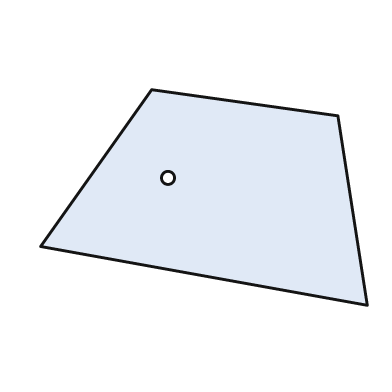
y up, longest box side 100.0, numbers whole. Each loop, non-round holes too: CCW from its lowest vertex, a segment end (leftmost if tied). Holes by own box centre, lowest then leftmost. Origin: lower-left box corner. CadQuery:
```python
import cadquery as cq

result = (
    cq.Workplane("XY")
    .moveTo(100.0, 0.0)
    .lineTo(91.0, 58.0)
    .lineTo(34.0, 66.0)
    .lineTo(0.0, 18.0)
    .close()
    .moveTo(39.0, 39.0)
    .circle(2.0)
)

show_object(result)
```